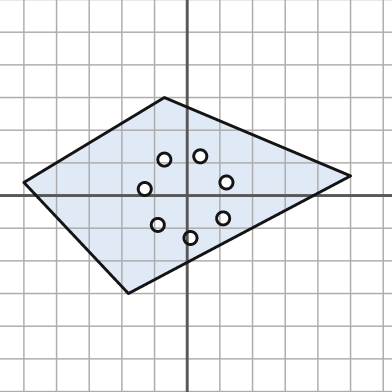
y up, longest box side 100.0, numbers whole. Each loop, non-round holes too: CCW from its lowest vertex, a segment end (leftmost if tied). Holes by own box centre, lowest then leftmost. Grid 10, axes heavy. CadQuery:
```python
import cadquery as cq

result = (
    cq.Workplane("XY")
    .moveTo(-18.0, -30.0)
    .lineTo(50.0, 6.0)
    .lineTo(-7.0, 30.0)
    .lineTo(-50.0, 4.0)
    .close()
    .moveTo(1.0, -13.0)
    .circle(2.0)
    .moveTo(-9.0, -9.0)
    .circle(2.0)
    .moveTo(11.0, -7.0)
    .circle(2.0)
    .moveTo(-13.0, 2.0)
    .circle(2.0)
    .moveTo(12.0, 4.0)
    .circle(2.0)
    .moveTo(-7.0, 11.0)
    .circle(2.0)
    .moveTo(4.0, 12.0)
    .circle(2.0)
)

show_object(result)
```